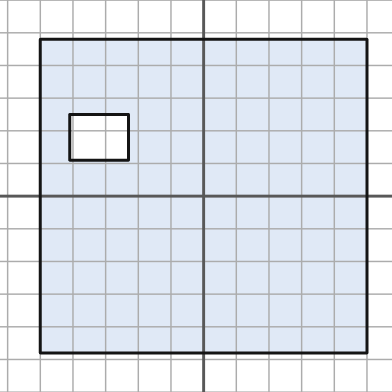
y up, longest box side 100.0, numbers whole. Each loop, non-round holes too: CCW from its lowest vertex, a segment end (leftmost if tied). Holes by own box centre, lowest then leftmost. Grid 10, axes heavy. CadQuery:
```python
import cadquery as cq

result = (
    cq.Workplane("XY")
    .moveTo(-50.0, -48.0)
    .lineTo(50.0, -48.0)
    .lineTo(50.0, 48.0)
    .lineTo(-50.0, 48.0)
    .close()
    .moveTo(-41.0, 11.0)
    .lineTo(-23.0, 11.0)
    .lineTo(-23.0, 25.0)
    .lineTo(-41.0, 25.0)
    .close()
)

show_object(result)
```